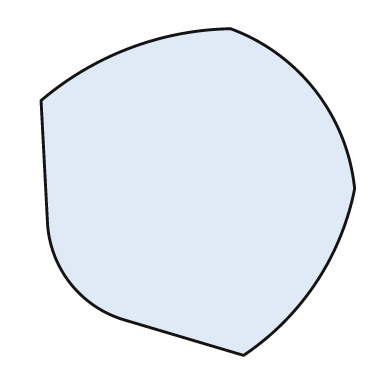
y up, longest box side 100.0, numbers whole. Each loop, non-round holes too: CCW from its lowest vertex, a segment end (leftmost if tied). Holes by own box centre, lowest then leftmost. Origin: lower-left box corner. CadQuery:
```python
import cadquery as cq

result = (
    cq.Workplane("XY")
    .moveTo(62.0, 0.0)
    .threePointArc((84.0, 22.0), (96.0, 51.0))
    .threePointArc((84.0, 81.0), (58.0, 100.0))
    .threePointArc((27.0, 94.0), (0.0, 78.0))
    .lineTo(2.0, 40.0)
    .threePointArc((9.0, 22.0), (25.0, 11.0))
    .close()
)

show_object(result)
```